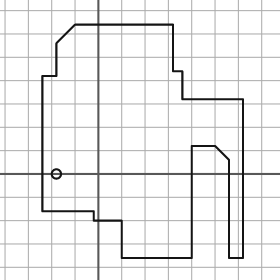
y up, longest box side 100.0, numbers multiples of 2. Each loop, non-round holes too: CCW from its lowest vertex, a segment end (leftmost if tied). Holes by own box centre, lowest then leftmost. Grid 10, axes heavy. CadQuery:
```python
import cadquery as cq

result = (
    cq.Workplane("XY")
    .moveTo(10.0, -36.0)
    .lineTo(40.0, -36.0)
    .lineTo(40.0, 12.0)
    .lineTo(50.0, 12.0)
    .lineTo(56.0, 6.0)
    .lineTo(56.0, -36.0)
    .lineTo(62.0, -36.0)
    .lineTo(62.0, 32.0)
    .lineTo(36.0, 32.0)
    .lineTo(36.0, 44.0)
    .lineTo(32.0, 44.0)
    .lineTo(32.0, 64.0)
    .lineTo(-10.0, 64.0)
    .lineTo(-18.0, 56.0)
    .lineTo(-18.0, 42.0)
    .lineTo(-24.0, 42.0)
    .lineTo(-24.0, -16.0)
    .lineTo(-2.0, -16.0)
    .lineTo(-2.0, -20.0)
    .lineTo(10.0, -20.0)
    .close()
    .moveTo(-18.0, 0.0)
    .circle(2.0)
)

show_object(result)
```